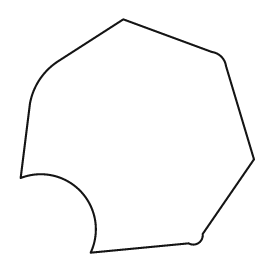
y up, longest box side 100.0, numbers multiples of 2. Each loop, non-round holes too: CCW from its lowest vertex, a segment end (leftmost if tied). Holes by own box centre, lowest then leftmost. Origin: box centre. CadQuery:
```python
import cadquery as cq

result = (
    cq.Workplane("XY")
    .moveTo(-20.0, -50.0)
    .lineTo(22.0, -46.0)
    .threePointArc((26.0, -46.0), (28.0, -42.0))
    .lineTo(50.0, -10.0)
    .lineTo(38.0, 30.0)
    .threePointArc((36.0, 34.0), (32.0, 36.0))
    .lineTo(-6.0, 50.0)
    .lineTo(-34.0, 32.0)
    .threePointArc((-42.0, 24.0), (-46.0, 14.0))
    .lineTo(-50.0, -18.0)
    .threePointArc((-24.0, -24.0), (-20.0, -50.0))
    .close()
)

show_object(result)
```